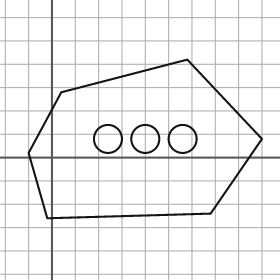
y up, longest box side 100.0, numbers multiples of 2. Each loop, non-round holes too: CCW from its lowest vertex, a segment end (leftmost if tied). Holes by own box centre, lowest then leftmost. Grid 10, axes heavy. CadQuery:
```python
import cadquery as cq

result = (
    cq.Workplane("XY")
    .moveTo(-2.0, -26.0)
    .lineTo(68.0, -24.0)
    .lineTo(90.0, 8.0)
    .lineTo(58.0, 42.0)
    .lineTo(4.0, 28.0)
    .lineTo(-10.0, 2.0)
    .close()
    .moveTo(24.0, 8.0)
    .circle(6.0)
    .moveTo(40.0, 8.0)
    .circle(6.0)
    .moveTo(56.0, 8.0)
    .circle(6.0)
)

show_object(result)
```